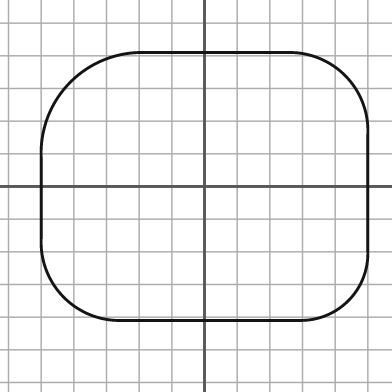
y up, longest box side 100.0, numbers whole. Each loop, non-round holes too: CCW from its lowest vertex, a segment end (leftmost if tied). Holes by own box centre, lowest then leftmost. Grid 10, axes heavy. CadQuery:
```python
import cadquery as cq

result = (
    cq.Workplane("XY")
    .moveTo(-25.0, -41.0)
    .lineTo(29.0, -41.0)
    .threePointArc((44.0, -35.0), (50.0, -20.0))
    .lineTo(50.0, 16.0)
    .threePointArc((43.0, 34.0), (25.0, 41.0))
    .lineTo(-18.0, 41.0)
    .threePointArc((-41.0, 32.0), (-50.0, 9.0))
    .lineTo(-50.0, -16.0)
    .threePointArc((-43.0, -34.0), (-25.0, -41.0))
    .close()
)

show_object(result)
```